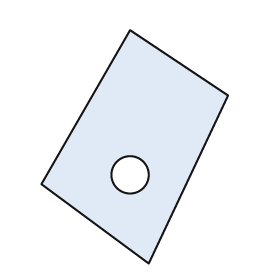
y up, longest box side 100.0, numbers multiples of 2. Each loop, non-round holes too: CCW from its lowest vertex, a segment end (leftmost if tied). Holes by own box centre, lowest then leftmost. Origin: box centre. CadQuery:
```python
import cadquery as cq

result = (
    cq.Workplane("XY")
    .moveTo(6.0, -50.0)
    .lineTo(40.0, 22.0)
    .lineTo(-2.0, 50.0)
    .lineTo(-40.0, -16.0)
    .close()
    .moveTo(-2.0, -12.0)
    .circle(8.0)
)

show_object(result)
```